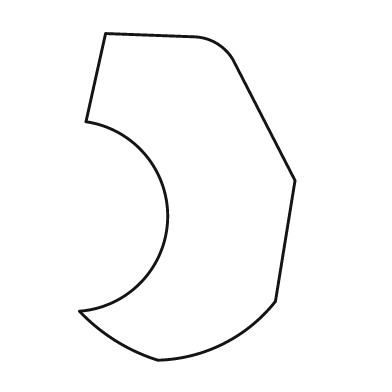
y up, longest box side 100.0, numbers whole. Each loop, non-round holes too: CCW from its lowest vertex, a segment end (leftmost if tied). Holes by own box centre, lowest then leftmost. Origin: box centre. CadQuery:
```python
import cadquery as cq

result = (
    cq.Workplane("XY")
    .moveTo(-9.0, -50.0)
    .threePointArc((11.0, -45.0), (27.0, -32.0))
    .lineTo(33.0, 5.0)
    .lineTo(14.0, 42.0)
    .threePointArc((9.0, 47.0), (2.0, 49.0))
    .lineTo(-25.0, 50.0)
    .lineTo(-31.0, 23.0)
    .threePointArc((-6.0, -7.0), (-33.0, -35.0))
    .threePointArc((-22.0, -44.0), (-9.0, -50.0))
    .close()
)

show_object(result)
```